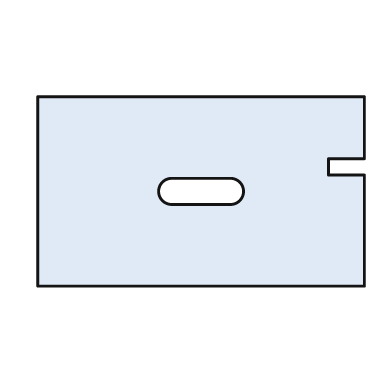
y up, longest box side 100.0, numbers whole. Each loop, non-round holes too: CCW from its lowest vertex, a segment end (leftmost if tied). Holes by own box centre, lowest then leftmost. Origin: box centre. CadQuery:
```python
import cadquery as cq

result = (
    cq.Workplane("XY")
    .moveTo(-50.0, -29.0)
    .lineTo(50.0, -29.0)
    .lineTo(50.0, 5.0)
    .lineTo(39.0, 5.0)
    .lineTo(39.0, 10.0)
    .lineTo(50.0, 10.0)
    .lineTo(50.0, 29.0)
    .lineTo(-50.0, 29.0)
    .close()
    .moveTo(-9.0, -4.0)
    .lineTo(9.0, -4.0)
    .threePointArc((13.0, 0.0), (9.0, 4.0))
    .lineTo(-9.0, 4.0)
    .threePointArc((-13.0, 0.0), (-9.0, -4.0))
    .close()
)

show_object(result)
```